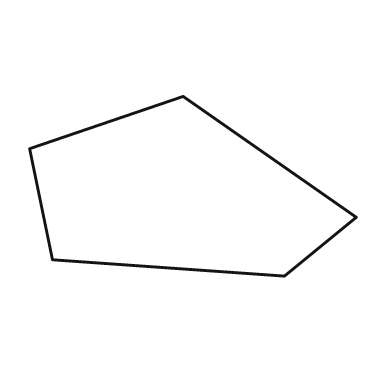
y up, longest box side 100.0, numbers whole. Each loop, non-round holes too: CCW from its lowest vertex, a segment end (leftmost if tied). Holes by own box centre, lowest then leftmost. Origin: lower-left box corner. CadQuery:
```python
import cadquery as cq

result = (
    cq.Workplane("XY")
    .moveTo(78.0, 0.0)
    .lineTo(100.0, 18.0)
    .lineTo(47.0, 55.0)
    .lineTo(0.0, 39.0)
    .lineTo(7.0, 5.0)
    .close()
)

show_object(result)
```